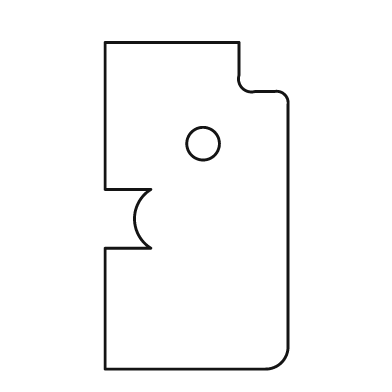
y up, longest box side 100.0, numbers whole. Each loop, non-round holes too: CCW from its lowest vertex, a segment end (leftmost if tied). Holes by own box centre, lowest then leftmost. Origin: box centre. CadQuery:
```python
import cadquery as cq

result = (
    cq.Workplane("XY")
    .moveTo(-28.0, -50.0)
    .lineTo(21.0, -50.0)
    .threePointArc((26.0, -48.0), (28.0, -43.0))
    .lineTo(28.0, 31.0)
    .threePointArc((27.0, 34.0), (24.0, 35.0))
    .lineTo(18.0, 35.0)
    .threePointArc((14.0, 36.0), (13.0, 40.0))
    .lineTo(13.0, 50.0)
    .lineTo(-28.0, 50.0)
    .lineTo(-28.0, 5.0)
    .lineTo(-14.0, 5.0)
    .threePointArc((-19.0, -4.0), (-14.0, -13.0))
    .lineTo(-28.0, -13.0)
    .close()
    .moveTo(2.0, 19.0)
    .circle(5.0)
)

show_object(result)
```